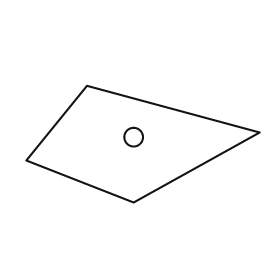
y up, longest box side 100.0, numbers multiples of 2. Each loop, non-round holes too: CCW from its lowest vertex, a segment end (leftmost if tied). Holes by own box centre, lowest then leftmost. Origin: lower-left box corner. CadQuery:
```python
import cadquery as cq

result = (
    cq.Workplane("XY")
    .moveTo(46.0, 0.0)
    .lineTo(100.0, 30.0)
    .lineTo(26.0, 50.0)
    .lineTo(0.0, 18.0)
    .close()
    .moveTo(46.0, 28.0)
    .circle(4.0)
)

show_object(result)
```